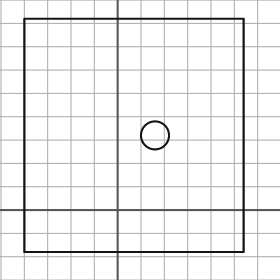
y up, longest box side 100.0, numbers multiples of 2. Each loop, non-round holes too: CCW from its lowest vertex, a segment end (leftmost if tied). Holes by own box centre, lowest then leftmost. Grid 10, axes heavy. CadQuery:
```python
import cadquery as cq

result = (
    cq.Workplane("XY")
    .moveTo(-40.0, -18.0)
    .lineTo(54.0, -18.0)
    .lineTo(54.0, 82.0)
    .lineTo(-40.0, 82.0)
    .close()
    .moveTo(16.0, 32.0)
    .circle(6.0)
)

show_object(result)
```